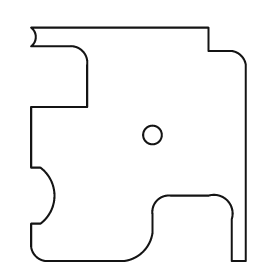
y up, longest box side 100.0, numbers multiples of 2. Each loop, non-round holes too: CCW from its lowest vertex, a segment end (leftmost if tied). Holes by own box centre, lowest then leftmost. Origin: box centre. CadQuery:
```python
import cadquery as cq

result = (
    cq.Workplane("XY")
    .moveTo(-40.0, -50.0)
    .lineTo(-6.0, -50.0)
    .threePointArc((2.0, -46.0), (6.0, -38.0))
    .lineTo(6.0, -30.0)
    .threePointArc((8.0, -24.0), (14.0, -22.0))
    .lineTo(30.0, -22.0)
    .threePointArc((38.0, -24.0), (40.0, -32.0))
    .lineTo(40.0, -50.0)
    .lineTo(46.0, -50.0)
    .lineTo(46.0, 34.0)
    .threePointArc((44.0, 38.0), (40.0, 40.0))
    .lineTo(30.0, 40.0)
    .lineTo(30.0, 50.0)
    .lineTo(-46.0, 50.0)
    .threePointArc((-44.0, 46.0), (-46.0, 42.0))
    .lineTo(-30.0, 42.0)
    .threePointArc((-24.0, 40.0), (-22.0, 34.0))
    .lineTo(-22.0, 16.0)
    .lineTo(-46.0, 16.0)
    .lineTo(-46.0, -10.0)
    .lineTo(-42.0, -10.0)
    .threePointArc((-36.0, -22.0), (-42.0, -34.0))
    .lineTo(-46.0, -34.0)
    .lineTo(-46.0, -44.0)
    .threePointArc((-44.0, -48.0), (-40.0, -50.0))
    .close()
    .moveTo(6.0, 4.0)
    .circle(4.0)
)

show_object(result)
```